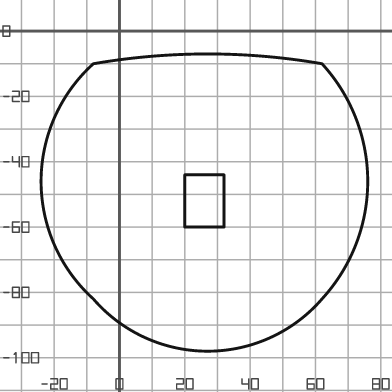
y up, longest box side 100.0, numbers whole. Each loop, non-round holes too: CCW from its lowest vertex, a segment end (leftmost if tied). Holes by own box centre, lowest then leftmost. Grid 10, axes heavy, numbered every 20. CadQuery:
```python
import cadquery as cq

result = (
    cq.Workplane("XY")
    .moveTo(-8.0, -82.0)
    .threePointArc((27.0, -98.0), (62.0, -82.0))
    .threePointArc((76.0, -46.0), (62.0, -10.0))
    .threePointArc((27.0, -7.0), (-8.0, -10.0))
    .threePointArc((-24.0, -46.0), (-8.0, -82.0))
    .close()
    .moveTo(20.0, -60.0)
    .lineTo(32.0, -60.0)
    .lineTo(32.0, -44.0)
    .lineTo(20.0, -44.0)
    .close()
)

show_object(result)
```